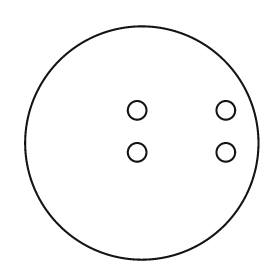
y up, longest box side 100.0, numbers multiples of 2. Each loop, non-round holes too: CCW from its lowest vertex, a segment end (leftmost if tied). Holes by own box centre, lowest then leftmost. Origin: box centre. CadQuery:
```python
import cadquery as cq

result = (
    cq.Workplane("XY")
    .moveTo(0.0, 0.0)
    .circle(50.0)
    .moveTo(-2.0, -4.0)
    .circle(4.0)
    .moveTo(36.0, -4.0)
    .circle(4.0)
    .moveTo(-2.0, 14.0)
    .circle(4.0)
    .moveTo(36.0, 14.0)
    .circle(4.0)
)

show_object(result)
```